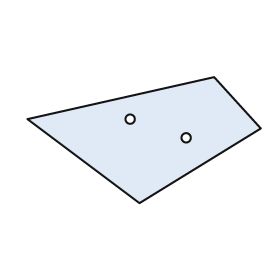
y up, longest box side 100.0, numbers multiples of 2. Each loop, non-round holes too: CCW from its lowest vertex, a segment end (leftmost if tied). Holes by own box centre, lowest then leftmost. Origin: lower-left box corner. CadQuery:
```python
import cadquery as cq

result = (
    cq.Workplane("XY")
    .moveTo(48.0, 0.0)
    .lineTo(100.0, 32.0)
    .lineTo(80.0, 54.0)
    .lineTo(0.0, 36.0)
    .close()
    .moveTo(68.0, 28.0)
    .circle(2.0)
    .moveTo(44.0, 36.0)
    .circle(2.0)
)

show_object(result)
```